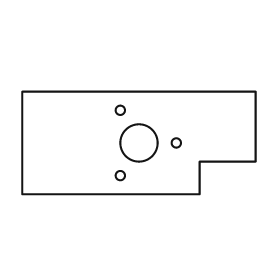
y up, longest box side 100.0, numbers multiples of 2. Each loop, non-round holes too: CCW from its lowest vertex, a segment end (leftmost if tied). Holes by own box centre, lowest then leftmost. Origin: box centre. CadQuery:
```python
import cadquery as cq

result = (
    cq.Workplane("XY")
    .moveTo(-50.0, -22.0)
    .lineTo(26.0, -22.0)
    .lineTo(26.0, -8.0)
    .lineTo(50.0, -8.0)
    .lineTo(50.0, 22.0)
    .lineTo(-50.0, 22.0)
    .close()
    .moveTo(-8.0, -14.0)
    .circle(2.0)
    .moveTo(0.0, 0.0)
    .circle(8.0)
    .moveTo(16.0, 0.0)
    .circle(2.0)
    .moveTo(-8.0, 14.0)
    .circle(2.0)
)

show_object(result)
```